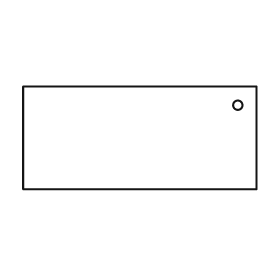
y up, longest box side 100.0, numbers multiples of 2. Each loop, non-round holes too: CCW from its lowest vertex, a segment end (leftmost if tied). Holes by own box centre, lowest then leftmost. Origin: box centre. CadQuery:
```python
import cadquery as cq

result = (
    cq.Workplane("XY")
    .moveTo(-50.0, -22.0)
    .lineTo(50.0, -22.0)
    .lineTo(50.0, 22.0)
    .lineTo(-50.0, 22.0)
    .close()
    .moveTo(42.0, 14.0)
    .circle(2.0)
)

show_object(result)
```